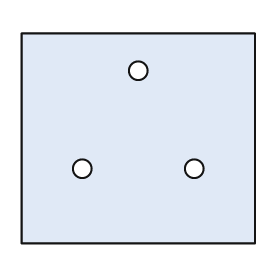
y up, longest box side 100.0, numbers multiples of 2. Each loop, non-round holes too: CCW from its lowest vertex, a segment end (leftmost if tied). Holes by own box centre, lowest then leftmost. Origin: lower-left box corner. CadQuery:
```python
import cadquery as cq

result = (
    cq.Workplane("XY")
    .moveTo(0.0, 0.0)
    .lineTo(100.0, 0.0)
    .lineTo(100.0, 90.0)
    .lineTo(0.0, 90.0)
    .close()
    .moveTo(26.0, 32.0)
    .circle(4.0)
    .moveTo(74.0, 32.0)
    .circle(4.0)
    .moveTo(50.0, 74.0)
    .circle(4.0)
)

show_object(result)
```